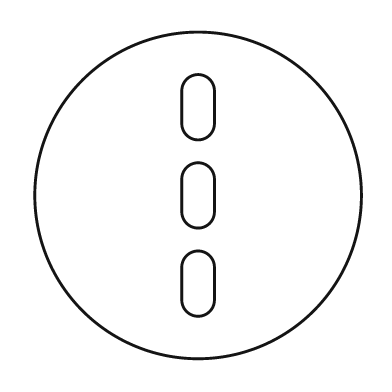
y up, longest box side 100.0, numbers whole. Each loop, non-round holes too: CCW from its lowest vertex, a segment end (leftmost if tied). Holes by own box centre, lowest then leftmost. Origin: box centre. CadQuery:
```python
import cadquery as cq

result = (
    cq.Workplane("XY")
    .moveTo(0.0, 0.0)
    .circle(50.0)
    .moveTo(-5.0, -32.0)
    .threePointArc((0.0, -37.0), (5.0, -32.0))
    .lineTo(5.0, -22.0)
    .threePointArc((0.0, -17.0), (-5.0, -22.0))
    .close()
    .moveTo(-5.0, -5.0)
    .threePointArc((0.0, -10.0), (5.0, -5.0))
    .lineTo(5.0, 5.0)
    .threePointArc((0.0, 10.0), (-5.0, 5.0))
    .close()
    .moveTo(-5.0, 22.0)
    .threePointArc((0.0, 17.0), (5.0, 22.0))
    .lineTo(5.0, 32.0)
    .threePointArc((0.0, 37.0), (-5.0, 32.0))
    .close()
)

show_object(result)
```